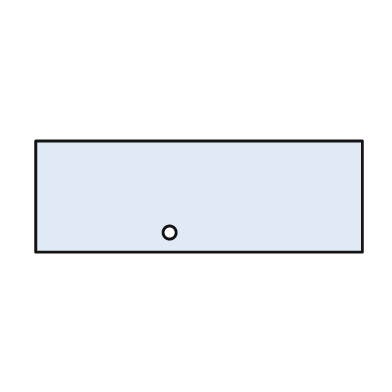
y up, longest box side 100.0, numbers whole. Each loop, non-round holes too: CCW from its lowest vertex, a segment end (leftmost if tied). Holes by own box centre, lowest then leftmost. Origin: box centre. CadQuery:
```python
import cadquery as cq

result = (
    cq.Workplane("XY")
    .moveTo(-50.0, -17.0)
    .lineTo(50.0, -17.0)
    .lineTo(50.0, 17.0)
    .lineTo(-50.0, 17.0)
    .close()
    .moveTo(-9.0, -11.0)
    .circle(2.0)
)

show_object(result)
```